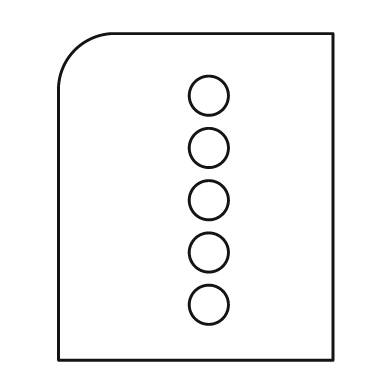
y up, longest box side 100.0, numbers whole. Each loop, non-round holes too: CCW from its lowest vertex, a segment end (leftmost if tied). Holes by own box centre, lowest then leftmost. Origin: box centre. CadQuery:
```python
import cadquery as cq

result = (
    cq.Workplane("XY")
    .moveTo(-42.0, -50.0)
    .lineTo(42.0, -50.0)
    .lineTo(42.0, 50.0)
    .lineTo(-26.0, 50.0)
    .threePointArc((-37.0, 45.0), (-42.0, 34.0))
    .close()
    .moveTo(4.0, -33.0)
    .circle(6.0)
    .moveTo(4.0, -17.0)
    .circle(6.0)
    .moveTo(4.0, -1.0)
    .circle(6.0)
    .moveTo(4.0, 15.0)
    .circle(6.0)
    .moveTo(4.0, 31.0)
    .circle(6.0)
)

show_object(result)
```